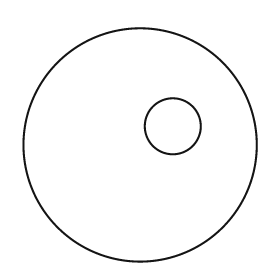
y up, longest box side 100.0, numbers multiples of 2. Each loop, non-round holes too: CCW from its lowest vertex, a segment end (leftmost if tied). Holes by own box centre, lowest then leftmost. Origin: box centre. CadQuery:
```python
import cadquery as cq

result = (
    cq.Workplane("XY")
    .moveTo(0.0, 0.0)
    .circle(50.0)
    .moveTo(14.0, 8.0)
    .circle(12.0)
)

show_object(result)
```